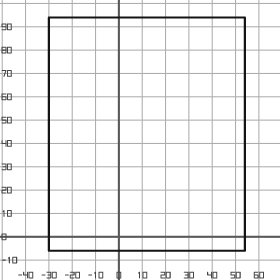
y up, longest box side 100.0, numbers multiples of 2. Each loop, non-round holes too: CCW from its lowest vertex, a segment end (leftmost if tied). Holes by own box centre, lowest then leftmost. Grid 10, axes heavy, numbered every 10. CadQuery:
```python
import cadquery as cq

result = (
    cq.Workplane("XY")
    .moveTo(-30.0, -6.0)
    .lineTo(54.0, -6.0)
    .lineTo(54.0, 94.0)
    .lineTo(-30.0, 94.0)
    .close()
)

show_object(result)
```